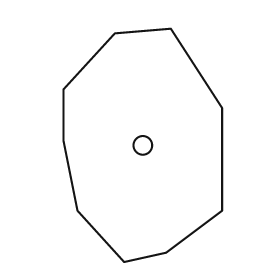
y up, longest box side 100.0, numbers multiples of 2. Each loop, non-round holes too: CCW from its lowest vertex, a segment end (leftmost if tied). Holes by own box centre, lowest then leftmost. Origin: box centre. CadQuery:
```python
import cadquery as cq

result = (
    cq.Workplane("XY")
    .moveTo(-8.0, -50.0)
    .lineTo(10.0, -46.0)
    .lineTo(34.0, -28.0)
    .lineTo(34.0, 16.0)
    .lineTo(12.0, 50.0)
    .lineTo(-12.0, 48.0)
    .lineTo(-34.0, 24.0)
    .lineTo(-34.0, 2.0)
    .lineTo(-28.0, -28.0)
    .close()
    .moveTo(0.0, 0.0)
    .circle(4.0)
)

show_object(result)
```